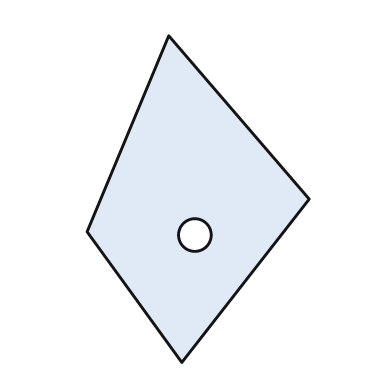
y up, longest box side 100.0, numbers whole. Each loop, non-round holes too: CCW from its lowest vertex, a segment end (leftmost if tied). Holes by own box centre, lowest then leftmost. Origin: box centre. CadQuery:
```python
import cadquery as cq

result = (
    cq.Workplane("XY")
    .moveTo(-5.0, -50.0)
    .lineTo(34.0, 0.0)
    .lineTo(-9.0, 50.0)
    .lineTo(-34.0, -10.0)
    .close()
    .moveTo(-1.0, -11.0)
    .circle(5.0)
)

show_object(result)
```